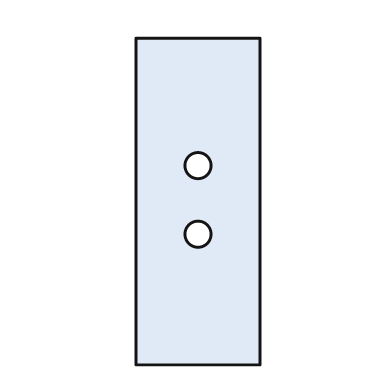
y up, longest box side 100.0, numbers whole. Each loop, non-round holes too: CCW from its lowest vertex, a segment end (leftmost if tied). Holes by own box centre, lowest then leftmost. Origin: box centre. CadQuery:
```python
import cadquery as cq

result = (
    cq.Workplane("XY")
    .moveTo(-19.0, -50.0)
    .lineTo(19.0, -50.0)
    .lineTo(19.0, 50.0)
    .lineTo(-19.0, 50.0)
    .close()
    .moveTo(0.0, -10.0)
    .circle(4.0)
    .moveTo(0.0, 11.0)
    .circle(4.0)
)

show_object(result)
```